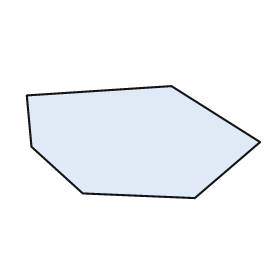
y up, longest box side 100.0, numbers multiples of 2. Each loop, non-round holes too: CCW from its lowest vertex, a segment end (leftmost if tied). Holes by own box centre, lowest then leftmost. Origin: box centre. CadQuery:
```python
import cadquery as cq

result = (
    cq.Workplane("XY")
    .moveTo(22.0, -24.0)
    .lineTo(50.0, 0.0)
    .lineTo(12.0, 24.0)
    .lineTo(-50.0, 20.0)
    .lineTo(-48.0, -2.0)
    .lineTo(-26.0, -22.0)
    .close()
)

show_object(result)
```